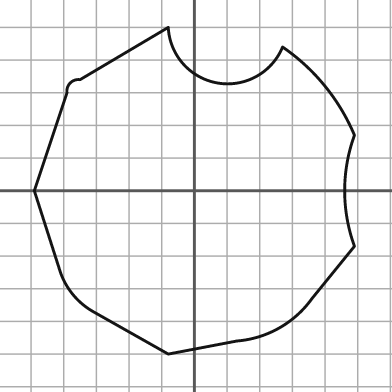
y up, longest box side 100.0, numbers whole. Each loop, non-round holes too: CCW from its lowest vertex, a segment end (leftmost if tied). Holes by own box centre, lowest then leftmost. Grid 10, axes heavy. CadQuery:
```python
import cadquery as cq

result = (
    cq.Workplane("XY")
    .moveTo(-8.0, -50.0)
    .lineTo(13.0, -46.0)
    .threePointArc((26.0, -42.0), (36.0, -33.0))
    .lineTo(49.0, -17.0)
    .threePointArc((46.0, 0.0), (49.0, 17.0))
    .threePointArc((40.0, 32.0), (27.0, 44.0))
    .threePointArc((7.0, 33.0), (-8.0, 50.0))
    .lineTo(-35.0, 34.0)
    .threePointArc((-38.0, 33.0), (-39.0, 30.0))
    .lineTo(-49.0, 0.0)
    .lineTo(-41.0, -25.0)
    .threePointArc((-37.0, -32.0), (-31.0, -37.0))
    .close()
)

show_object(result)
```